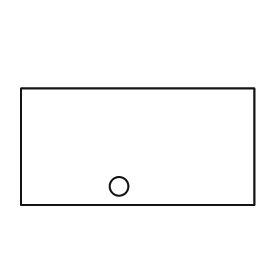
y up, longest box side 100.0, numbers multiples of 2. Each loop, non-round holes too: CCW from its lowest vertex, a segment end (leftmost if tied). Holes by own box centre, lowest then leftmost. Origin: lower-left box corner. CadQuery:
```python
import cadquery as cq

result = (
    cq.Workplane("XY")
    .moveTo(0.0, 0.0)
    .lineTo(100.0, 0.0)
    .lineTo(100.0, 50.0)
    .lineTo(0.0, 50.0)
    .close()
    .moveTo(42.0, 8.0)
    .circle(4.0)
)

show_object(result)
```